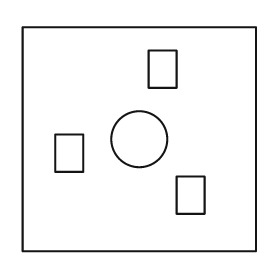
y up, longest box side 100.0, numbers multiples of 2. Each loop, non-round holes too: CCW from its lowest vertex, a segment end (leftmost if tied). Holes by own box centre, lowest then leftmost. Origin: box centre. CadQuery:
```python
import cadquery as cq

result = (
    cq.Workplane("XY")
    .moveTo(-50.0, -48.0)
    .lineTo(50.0, -48.0)
    .lineTo(50.0, 48.0)
    .lineTo(-50.0, 48.0)
    .close()
    .moveTo(16.0, -32.0)
    .lineTo(28.0, -32.0)
    .lineTo(28.0, -16.0)
    .lineTo(16.0, -16.0)
    .close()
    .moveTo(-36.0, -14.0)
    .lineTo(-24.0, -14.0)
    .lineTo(-24.0, 2.0)
    .lineTo(-36.0, 2.0)
    .close()
    .moveTo(0.0, 0.0)
    .circle(12.0)
    .moveTo(4.0, 22.0)
    .lineTo(16.0, 22.0)
    .lineTo(16.0, 38.0)
    .lineTo(4.0, 38.0)
    .close()
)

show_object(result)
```